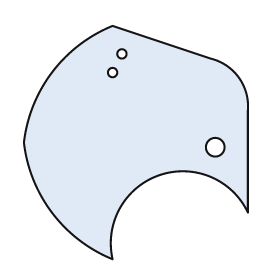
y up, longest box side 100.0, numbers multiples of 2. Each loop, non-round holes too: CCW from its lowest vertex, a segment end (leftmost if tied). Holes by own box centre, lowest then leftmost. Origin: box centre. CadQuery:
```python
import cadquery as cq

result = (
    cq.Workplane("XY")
    .moveTo(-10.0, -50.0)
    .threePointArc((10.0, -14.0), (48.0, -30.0))
    .lineTo(48.0, 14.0)
    .threePointArc((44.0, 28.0), (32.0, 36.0))
    .lineTo(-10.0, 50.0)
    .threePointArc((-36.0, 30.0), (-48.0, 0.0))
    .threePointArc((-36.0, -30.0), (-10.0, -50.0))
    .close()
    .moveTo(34.0, -2.0)
    .circle(4.0)
    .moveTo(-10.0, 30.0)
    .circle(2.0)
    .moveTo(-6.0, 38.0)
    .circle(2.0)
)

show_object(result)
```